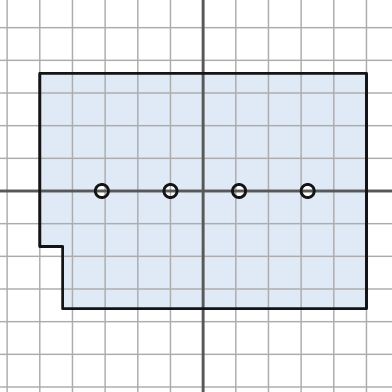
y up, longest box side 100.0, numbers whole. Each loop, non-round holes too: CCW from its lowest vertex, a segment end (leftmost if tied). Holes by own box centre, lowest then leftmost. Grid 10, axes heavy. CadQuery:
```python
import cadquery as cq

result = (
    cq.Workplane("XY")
    .moveTo(-43.0, -36.0)
    .lineTo(50.0, -36.0)
    .lineTo(50.0, 36.0)
    .lineTo(-50.0, 36.0)
    .lineTo(-50.0, -17.0)
    .lineTo(-43.0, -17.0)
    .close()
    .moveTo(-31.0, 0.0)
    .circle(2.0)
    .moveTo(-10.0, 0.0)
    .circle(2.0)
    .moveTo(11.0, 0.0)
    .circle(2.0)
    .moveTo(32.0, 0.0)
    .circle(2.0)
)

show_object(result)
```